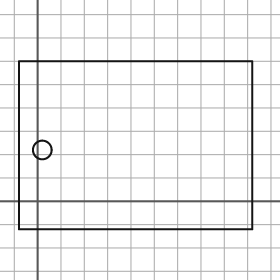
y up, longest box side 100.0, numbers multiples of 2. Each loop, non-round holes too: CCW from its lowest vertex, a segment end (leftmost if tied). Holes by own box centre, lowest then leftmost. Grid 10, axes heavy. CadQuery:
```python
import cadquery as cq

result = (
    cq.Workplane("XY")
    .moveTo(-8.0, -12.0)
    .lineTo(92.0, -12.0)
    .lineTo(92.0, 60.0)
    .lineTo(-8.0, 60.0)
    .close()
    .moveTo(2.0, 22.0)
    .circle(4.0)
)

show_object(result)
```